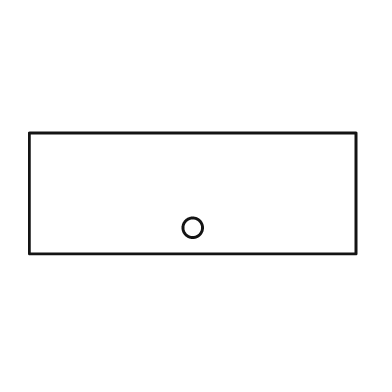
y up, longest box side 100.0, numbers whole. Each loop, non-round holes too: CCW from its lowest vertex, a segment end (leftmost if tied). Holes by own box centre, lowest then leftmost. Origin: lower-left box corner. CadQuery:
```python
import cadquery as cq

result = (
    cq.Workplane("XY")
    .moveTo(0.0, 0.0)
    .lineTo(100.0, 0.0)
    .lineTo(100.0, 37.0)
    .lineTo(0.0, 37.0)
    .close()
    .moveTo(50.0, 8.0)
    .circle(3.0)
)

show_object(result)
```